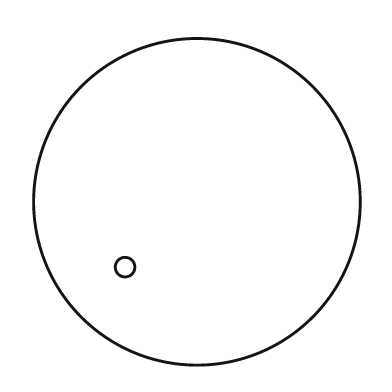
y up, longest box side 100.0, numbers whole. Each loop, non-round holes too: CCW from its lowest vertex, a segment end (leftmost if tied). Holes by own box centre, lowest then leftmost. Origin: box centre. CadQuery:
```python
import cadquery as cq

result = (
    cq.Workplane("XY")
    .moveTo(0.0, 0.0)
    .circle(50.0)
    .moveTo(-22.0, -20.0)
    .circle(3.0)
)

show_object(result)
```